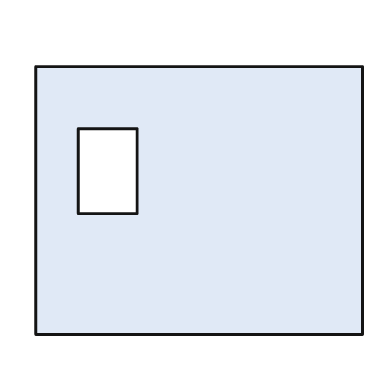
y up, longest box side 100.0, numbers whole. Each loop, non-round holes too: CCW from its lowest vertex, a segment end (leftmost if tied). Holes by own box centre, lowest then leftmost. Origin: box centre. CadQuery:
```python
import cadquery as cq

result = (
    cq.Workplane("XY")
    .moveTo(-50.0, -41.0)
    .lineTo(50.0, -41.0)
    .lineTo(50.0, 41.0)
    .lineTo(-50.0, 41.0)
    .close()
    .moveTo(-37.0, -4.0)
    .lineTo(-19.0, -4.0)
    .lineTo(-19.0, 22.0)
    .lineTo(-37.0, 22.0)
    .close()
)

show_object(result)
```